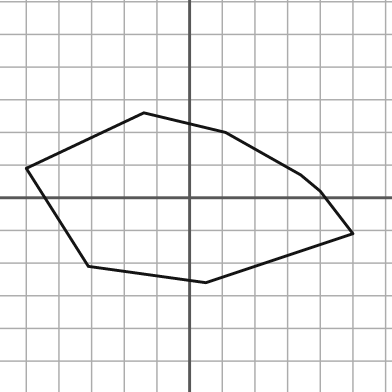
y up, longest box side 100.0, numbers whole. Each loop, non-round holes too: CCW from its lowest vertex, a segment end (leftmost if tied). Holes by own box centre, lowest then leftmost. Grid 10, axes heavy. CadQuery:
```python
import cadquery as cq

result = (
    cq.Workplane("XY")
    .moveTo(5.0, -26.0)
    .lineTo(50.0, -11.0)
    .lineTo(40.0, 2.0)
    .lineTo(34.0, 7.0)
    .lineTo(11.0, 20.0)
    .lineTo(-14.0, 26.0)
    .lineTo(-50.0, 9.0)
    .lineTo(-31.0, -21.0)
    .close()
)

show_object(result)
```